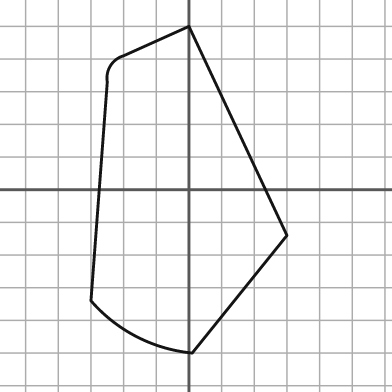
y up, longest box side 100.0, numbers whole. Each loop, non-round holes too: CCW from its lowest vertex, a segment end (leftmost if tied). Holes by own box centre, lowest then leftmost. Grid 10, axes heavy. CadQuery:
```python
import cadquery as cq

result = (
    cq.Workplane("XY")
    .moveTo(1.0, -50.0)
    .lineTo(30.0, -14.0)
    .lineTo(0.0, 50.0)
    .lineTo(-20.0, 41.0)
    .threePointArc((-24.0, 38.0), (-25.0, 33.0))
    .lineTo(-30.0, -34.0)
    .threePointArc((-16.0, -45.0), (1.0, -50.0))
    .close()
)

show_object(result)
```